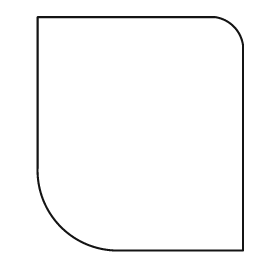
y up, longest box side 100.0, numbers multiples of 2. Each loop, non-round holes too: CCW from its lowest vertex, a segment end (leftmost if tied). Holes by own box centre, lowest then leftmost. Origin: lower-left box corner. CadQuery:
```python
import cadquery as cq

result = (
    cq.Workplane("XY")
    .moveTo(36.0, 0.0)
    .lineTo(88.0, 0.0)
    .lineTo(88.0, 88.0)
    .threePointArc((84.0, 96.0), (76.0, 100.0))
    .lineTo(0.0, 100.0)
    .lineTo(0.0, 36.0)
    .threePointArc((10.0, 10.0), (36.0, 0.0))
    .close()
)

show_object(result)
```